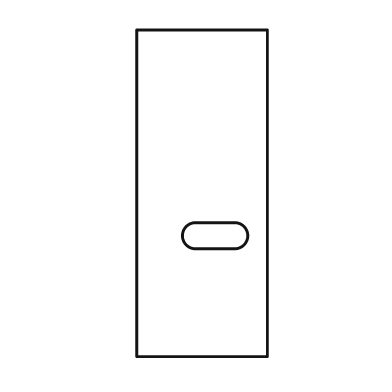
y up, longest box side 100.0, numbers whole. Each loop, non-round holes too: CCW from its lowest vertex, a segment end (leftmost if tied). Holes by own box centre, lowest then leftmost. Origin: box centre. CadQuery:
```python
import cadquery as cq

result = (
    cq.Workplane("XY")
    .moveTo(-20.0, -50.0)
    .lineTo(20.0, -50.0)
    .lineTo(20.0, 50.0)
    .lineTo(-20.0, 50.0)
    .close()
    .moveTo(-2.0, -17.0)
    .lineTo(10.0, -17.0)
    .threePointArc((14.0, -13.0), (10.0, -9.0))
    .lineTo(-2.0, -9.0)
    .threePointArc((-6.0, -13.0), (-2.0, -17.0))
    .close()
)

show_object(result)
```